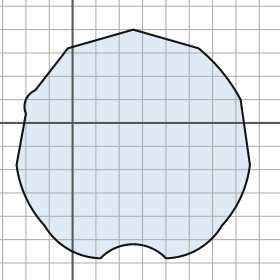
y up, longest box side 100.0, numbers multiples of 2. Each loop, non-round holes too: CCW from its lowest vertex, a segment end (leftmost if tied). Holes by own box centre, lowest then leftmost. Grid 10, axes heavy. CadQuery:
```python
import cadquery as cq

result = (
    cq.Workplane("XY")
    .moveTo(12.0, -58.0)
    .threePointArc((26.0, -52.0), (40.0, -58.0))
    .threePointArc((54.0, -54.0), (64.0, -44.0))
    .threePointArc((72.0, -32.0), (76.0, -18.0))
    .lineTo(72.0, 10.0)
    .threePointArc((64.0, 22.0), (54.0, 32.0))
    .lineTo(26.0, 40.0)
    .lineTo(-2.0, 32.0)
    .lineTo(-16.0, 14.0)
    .threePointArc((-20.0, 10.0), (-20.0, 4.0))
    .lineTo(-24.0, -18.0)
    .threePointArc((-20.0, -32.0), (-12.0, -44.0))
    .threePointArc((-2.0, -54.0), (12.0, -58.0))
    .close()
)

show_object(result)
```